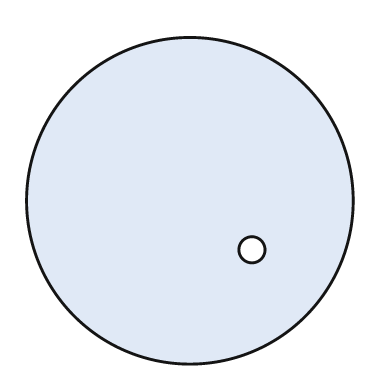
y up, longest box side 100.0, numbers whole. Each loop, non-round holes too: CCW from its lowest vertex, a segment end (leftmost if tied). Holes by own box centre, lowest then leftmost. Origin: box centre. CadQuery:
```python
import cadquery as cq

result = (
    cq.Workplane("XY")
    .moveTo(0.0, 0.0)
    .circle(50.0)
    .moveTo(19.0, -15.0)
    .circle(4.0)
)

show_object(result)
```